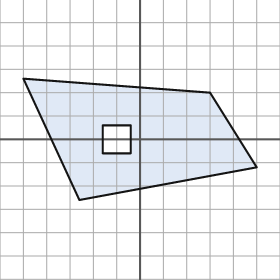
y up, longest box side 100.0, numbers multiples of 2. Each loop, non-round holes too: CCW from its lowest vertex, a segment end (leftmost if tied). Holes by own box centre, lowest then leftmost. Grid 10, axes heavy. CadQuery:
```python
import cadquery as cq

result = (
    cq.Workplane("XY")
    .moveTo(-26.0, -26.0)
    .lineTo(50.0, -12.0)
    .lineTo(30.0, 20.0)
    .lineTo(-50.0, 26.0)
    .close()
    .moveTo(-16.0, -6.0)
    .lineTo(-4.0, -6.0)
    .lineTo(-4.0, 6.0)
    .lineTo(-16.0, 6.0)
    .close()
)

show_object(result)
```